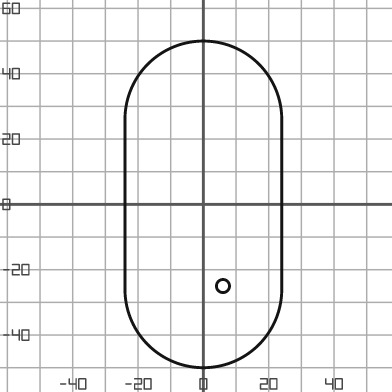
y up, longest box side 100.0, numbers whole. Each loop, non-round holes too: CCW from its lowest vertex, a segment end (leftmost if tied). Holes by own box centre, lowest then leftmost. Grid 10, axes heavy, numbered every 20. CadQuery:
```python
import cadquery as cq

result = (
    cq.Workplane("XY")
    .moveTo(-24.0, -26.0)
    .threePointArc((0.0, -50.0), (24.0, -26.0))
    .lineTo(24.0, 26.0)
    .threePointArc((0.0, 50.0), (-24.0, 26.0))
    .close()
    .moveTo(6.0, -25.0)
    .circle(2.0)
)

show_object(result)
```